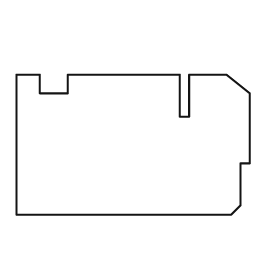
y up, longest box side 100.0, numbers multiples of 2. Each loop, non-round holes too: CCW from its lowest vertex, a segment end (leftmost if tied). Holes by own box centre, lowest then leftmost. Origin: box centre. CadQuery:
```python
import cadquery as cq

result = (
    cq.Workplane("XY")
    .moveTo(-50.0, -30.0)
    .lineTo(42.0, -30.0)
    .lineTo(46.0, -26.0)
    .lineTo(46.0, -8.0)
    .lineTo(50.0, -8.0)
    .lineTo(50.0, 22.0)
    .lineTo(40.0, 30.0)
    .lineTo(24.0, 30.0)
    .lineTo(24.0, 12.0)
    .lineTo(20.0, 12.0)
    .lineTo(20.0, 30.0)
    .lineTo(-28.0, 30.0)
    .lineTo(-28.0, 22.0)
    .lineTo(-40.0, 22.0)
    .lineTo(-40.0, 30.0)
    .lineTo(-50.0, 30.0)
    .close()
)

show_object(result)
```